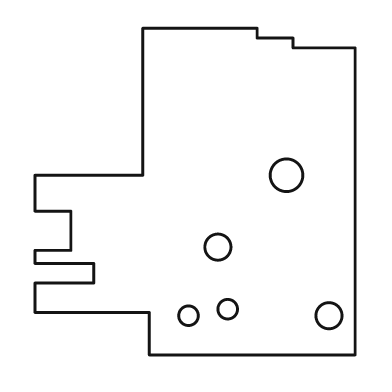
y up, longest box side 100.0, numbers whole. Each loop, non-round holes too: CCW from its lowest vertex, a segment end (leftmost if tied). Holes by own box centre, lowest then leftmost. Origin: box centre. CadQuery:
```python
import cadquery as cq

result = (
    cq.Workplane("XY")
    .moveTo(-14.0, -50.0)
    .lineTo(49.0, -50.0)
    .lineTo(49.0, 44.0)
    .lineTo(30.0, 44.0)
    .lineTo(30.0, 47.0)
    .lineTo(19.0, 47.0)
    .lineTo(19.0, 50.0)
    .lineTo(-16.0, 50.0)
    .lineTo(-16.0, 5.0)
    .lineTo(-49.0, 5.0)
    .lineTo(-49.0, -6.0)
    .lineTo(-38.0, -6.0)
    .lineTo(-38.0, -18.0)
    .lineTo(-49.0, -18.0)
    .lineTo(-49.0, -22.0)
    .lineTo(-31.0, -22.0)
    .lineTo(-31.0, -28.0)
    .lineTo(-49.0, -28.0)
    .lineTo(-49.0, -37.0)
    .lineTo(-14.0, -37.0)
    .close()
    .moveTo(-2.0, -38.0)
    .circle(3.0)
    .moveTo(41.0, -38.0)
    .circle(4.0)
    .moveTo(10.0, -36.0)
    .circle(3.0)
    .moveTo(7.0, -17.0)
    .circle(4.0)
    .moveTo(28.0, 5.0)
    .circle(5.0)
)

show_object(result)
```